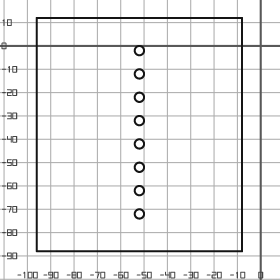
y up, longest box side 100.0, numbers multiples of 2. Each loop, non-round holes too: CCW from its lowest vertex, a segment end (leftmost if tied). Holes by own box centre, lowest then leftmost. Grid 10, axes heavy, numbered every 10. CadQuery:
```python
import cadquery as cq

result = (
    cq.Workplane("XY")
    .moveTo(-96.0, -88.0)
    .lineTo(-8.0, -88.0)
    .lineTo(-8.0, 12.0)
    .lineTo(-96.0, 12.0)
    .close()
    .moveTo(-52.0, -72.0)
    .circle(2.0)
    .moveTo(-52.0, -62.0)
    .circle(2.0)
    .moveTo(-52.0, -52.0)
    .circle(2.0)
    .moveTo(-52.0, -42.0)
    .circle(2.0)
    .moveTo(-52.0, -32.0)
    .circle(2.0)
    .moveTo(-52.0, -22.0)
    .circle(2.0)
    .moveTo(-52.0, -12.0)
    .circle(2.0)
    .moveTo(-52.0, -2.0)
    .circle(2.0)
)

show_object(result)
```